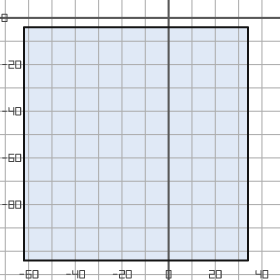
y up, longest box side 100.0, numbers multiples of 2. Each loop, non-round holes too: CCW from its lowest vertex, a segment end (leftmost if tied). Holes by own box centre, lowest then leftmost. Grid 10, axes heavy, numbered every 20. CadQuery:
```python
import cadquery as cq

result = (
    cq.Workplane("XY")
    .moveTo(-62.0, -104.0)
    .lineTo(34.0, -104.0)
    .lineTo(34.0, -4.0)
    .lineTo(-62.0, -4.0)
    .close()
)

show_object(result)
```